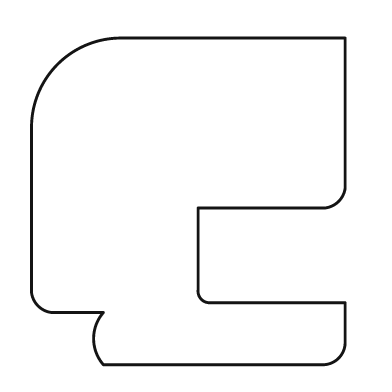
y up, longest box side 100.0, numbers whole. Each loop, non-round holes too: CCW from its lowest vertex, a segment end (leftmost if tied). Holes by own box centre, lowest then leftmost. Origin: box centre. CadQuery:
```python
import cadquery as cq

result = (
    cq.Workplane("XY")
    .moveTo(-26.0, -50.0)
    .lineTo(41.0, -50.0)
    .threePointArc((46.0, -48.0), (48.0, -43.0))
    .lineTo(48.0, -31.0)
    .lineTo(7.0, -31.0)
    .threePointArc((4.0, -30.0), (3.0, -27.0))
    .lineTo(3.0, -2.0)
    .lineTo(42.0, -2.0)
    .threePointArc((46.0, 0.0), (48.0, 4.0))
    .lineTo(48.0, 50.0)
    .lineTo(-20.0, 50.0)
    .threePointArc((-40.0, 42.0), (-48.0, 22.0))
    .lineTo(-48.0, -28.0)
    .threePointArc((-46.0, -32.0), (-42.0, -34.0))
    .lineTo(-26.0, -34.0)
    .threePointArc((-29.0, -42.0), (-26.0, -50.0))
    .close()
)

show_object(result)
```